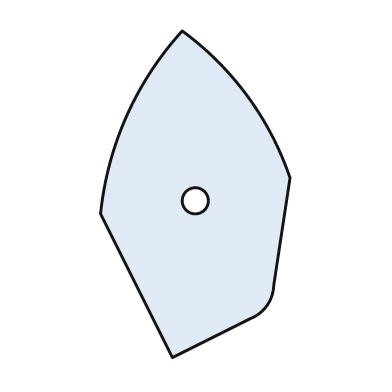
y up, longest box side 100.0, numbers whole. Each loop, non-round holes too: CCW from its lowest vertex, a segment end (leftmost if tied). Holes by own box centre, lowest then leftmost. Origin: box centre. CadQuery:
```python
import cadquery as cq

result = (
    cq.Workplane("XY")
    .moveTo(-7.0, -50.0)
    .lineTo(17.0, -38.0)
    .threePointArc((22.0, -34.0), (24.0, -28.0))
    .lineTo(29.0, 5.0)
    .threePointArc((16.0, 30.0), (-4.0, 50.0))
    .threePointArc((-21.0, 24.0), (-29.0, -6.0))
    .close()
    .moveTo(0.0, -2.0)
    .circle(4.0)
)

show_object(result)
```